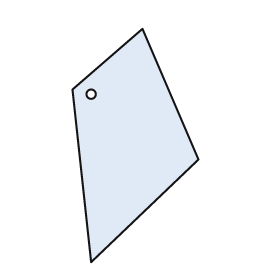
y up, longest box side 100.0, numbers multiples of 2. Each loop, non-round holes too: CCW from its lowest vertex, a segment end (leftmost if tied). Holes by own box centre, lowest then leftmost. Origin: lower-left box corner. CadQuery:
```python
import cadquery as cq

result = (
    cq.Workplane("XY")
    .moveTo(8.0, 0.0)
    .lineTo(54.0, 44.0)
    .lineTo(30.0, 100.0)
    .lineTo(0.0, 74.0)
    .close()
    .moveTo(8.0, 72.0)
    .circle(2.0)
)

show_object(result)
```